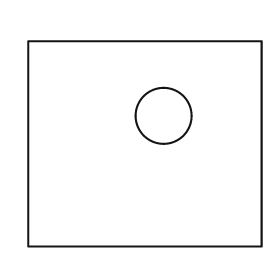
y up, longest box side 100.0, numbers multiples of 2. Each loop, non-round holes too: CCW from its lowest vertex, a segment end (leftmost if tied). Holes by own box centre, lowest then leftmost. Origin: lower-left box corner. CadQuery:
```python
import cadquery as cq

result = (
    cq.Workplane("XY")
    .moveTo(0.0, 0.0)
    .lineTo(100.0, 0.0)
    .lineTo(100.0, 88.0)
    .lineTo(0.0, 88.0)
    .close()
    .moveTo(58.0, 56.0)
    .circle(12.0)
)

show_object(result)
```